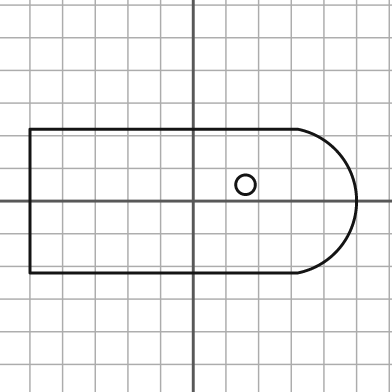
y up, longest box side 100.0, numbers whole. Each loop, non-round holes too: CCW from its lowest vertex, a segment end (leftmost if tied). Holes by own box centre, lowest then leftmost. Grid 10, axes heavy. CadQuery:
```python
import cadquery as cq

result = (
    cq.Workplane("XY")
    .moveTo(-50.0, -22.0)
    .lineTo(32.0, -22.0)
    .threePointArc((50.0, 0.0), (32.0, 22.0))
    .lineTo(-50.0, 22.0)
    .close()
    .moveTo(16.0, 5.0)
    .circle(3.0)
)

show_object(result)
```